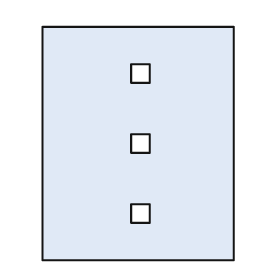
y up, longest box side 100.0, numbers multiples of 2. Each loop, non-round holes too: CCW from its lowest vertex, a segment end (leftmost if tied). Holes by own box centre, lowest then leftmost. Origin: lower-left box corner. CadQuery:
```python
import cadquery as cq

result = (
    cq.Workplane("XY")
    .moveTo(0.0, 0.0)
    .lineTo(82.0, 0.0)
    .lineTo(82.0, 100.0)
    .lineTo(0.0, 100.0)
    .close()
    .moveTo(38.0, 16.0)
    .lineTo(46.0, 16.0)
    .lineTo(46.0, 24.0)
    .lineTo(38.0, 24.0)
    .close()
    .moveTo(38.0, 46.0)
    .lineTo(46.0, 46.0)
    .lineTo(46.0, 54.0)
    .lineTo(38.0, 54.0)
    .close()
    .moveTo(38.0, 76.0)
    .lineTo(46.0, 76.0)
    .lineTo(46.0, 84.0)
    .lineTo(38.0, 84.0)
    .close()
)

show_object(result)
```